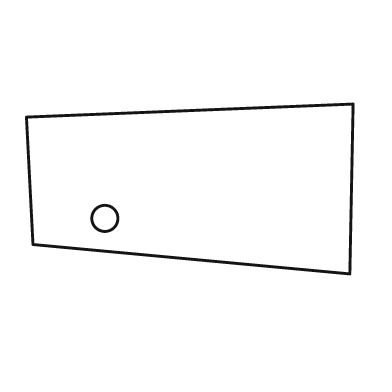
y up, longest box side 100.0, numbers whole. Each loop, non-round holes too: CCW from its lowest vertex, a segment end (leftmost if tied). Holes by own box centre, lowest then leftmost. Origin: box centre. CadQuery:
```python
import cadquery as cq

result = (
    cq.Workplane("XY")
    .moveTo(49.0, -26.0)
    .lineTo(50.0, 26.0)
    .lineTo(-50.0, 22.0)
    .lineTo(-48.0, -17.0)
    .close()
    .moveTo(-26.0, -9.0)
    .circle(4.0)
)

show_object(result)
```